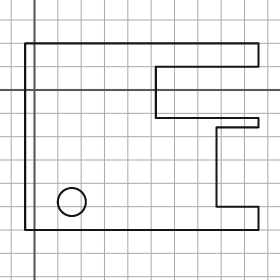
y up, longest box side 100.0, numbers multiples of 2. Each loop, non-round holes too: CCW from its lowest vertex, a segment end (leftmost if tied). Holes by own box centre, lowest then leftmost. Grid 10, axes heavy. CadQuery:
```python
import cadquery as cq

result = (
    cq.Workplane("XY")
    .moveTo(-4.0, -60.0)
    .lineTo(96.0, -60.0)
    .lineTo(96.0, -50.0)
    .lineTo(78.0, -50.0)
    .lineTo(78.0, -16.0)
    .lineTo(96.0, -16.0)
    .lineTo(96.0, -12.0)
    .lineTo(52.0, -12.0)
    .lineTo(52.0, 10.0)
    .lineTo(96.0, 10.0)
    .lineTo(96.0, 20.0)
    .lineTo(-4.0, 20.0)
    .close()
    .moveTo(16.0, -48.0)
    .circle(6.0)
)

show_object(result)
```